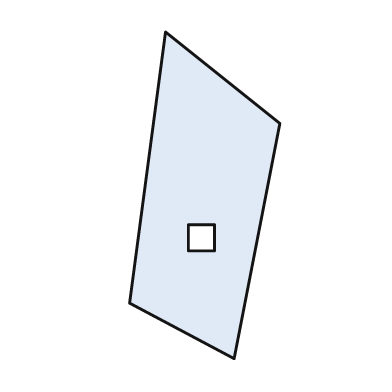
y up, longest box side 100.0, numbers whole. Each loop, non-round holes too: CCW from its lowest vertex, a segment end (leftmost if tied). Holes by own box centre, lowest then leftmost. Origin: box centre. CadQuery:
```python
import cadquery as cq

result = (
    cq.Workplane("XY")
    .moveTo(9.0, -50.0)
    .lineTo(23.0, 22.0)
    .lineTo(-12.0, 50.0)
    .lineTo(-23.0, -33.0)
    .close()
    .moveTo(-5.0, -17.0)
    .lineTo(3.0, -17.0)
    .lineTo(3.0, -9.0)
    .lineTo(-5.0, -9.0)
    .close()
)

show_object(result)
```